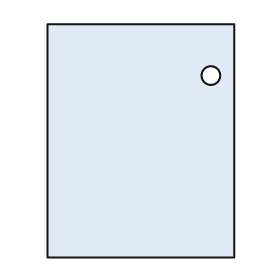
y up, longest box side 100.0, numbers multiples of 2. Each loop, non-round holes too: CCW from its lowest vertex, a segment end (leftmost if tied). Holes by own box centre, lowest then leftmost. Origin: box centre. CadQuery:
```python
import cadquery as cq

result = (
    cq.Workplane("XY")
    .moveTo(-40.0, -50.0)
    .lineTo(40.0, -50.0)
    .lineTo(40.0, 50.0)
    .lineTo(-40.0, 50.0)
    .close()
    .moveTo(30.0, 28.0)
    .circle(4.0)
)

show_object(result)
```